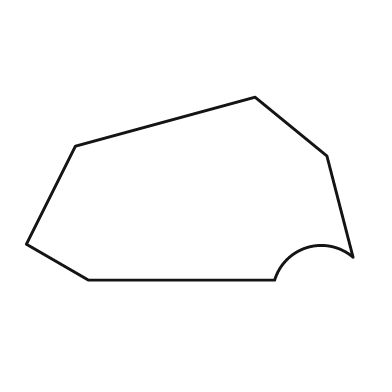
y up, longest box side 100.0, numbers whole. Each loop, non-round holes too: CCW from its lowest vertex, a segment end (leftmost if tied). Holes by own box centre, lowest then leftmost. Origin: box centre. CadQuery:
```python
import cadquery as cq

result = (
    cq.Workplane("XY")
    .moveTo(-31.0, -28.0)
    .lineTo(26.0, -28.0)
    .threePointArc((36.0, -18.0), (50.0, -21.0))
    .lineTo(42.0, 10.0)
    .lineTo(20.0, 28.0)
    .lineTo(-35.0, 13.0)
    .lineTo(-50.0, -17.0)
    .close()
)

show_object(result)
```